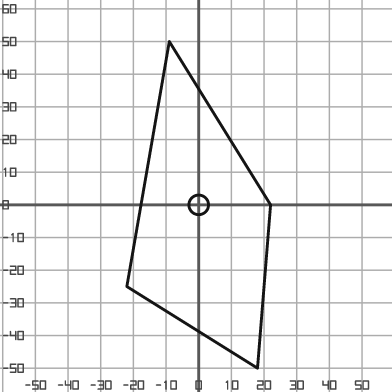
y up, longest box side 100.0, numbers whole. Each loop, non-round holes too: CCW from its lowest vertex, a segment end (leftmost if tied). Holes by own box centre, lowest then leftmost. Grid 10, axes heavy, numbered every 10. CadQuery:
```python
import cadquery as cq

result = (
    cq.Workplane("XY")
    .moveTo(18.0, -50.0)
    .lineTo(22.0, 0.0)
    .lineTo(-9.0, 50.0)
    .lineTo(-22.0, -25.0)
    .close()
    .moveTo(0.0, 0.0)
    .circle(3.0)
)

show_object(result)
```